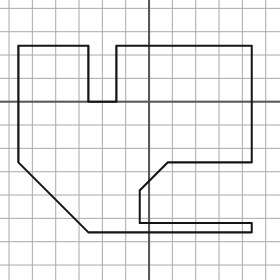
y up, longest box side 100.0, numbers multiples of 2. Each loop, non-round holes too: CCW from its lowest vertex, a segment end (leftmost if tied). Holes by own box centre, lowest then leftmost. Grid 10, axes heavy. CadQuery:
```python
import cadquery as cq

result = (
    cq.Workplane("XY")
    .moveTo(-26.0, -56.0)
    .lineTo(44.0, -56.0)
    .lineTo(44.0, -52.0)
    .lineTo(-4.0, -52.0)
    .lineTo(-4.0, -38.0)
    .lineTo(8.0, -26.0)
    .lineTo(44.0, -26.0)
    .lineTo(44.0, 24.0)
    .lineTo(-14.0, 24.0)
    .lineTo(-14.0, 0.0)
    .lineTo(-26.0, 0.0)
    .lineTo(-26.0, 24.0)
    .lineTo(-56.0, 24.0)
    .lineTo(-56.0, -26.0)
    .close()
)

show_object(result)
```